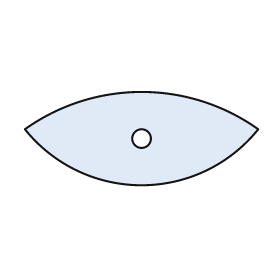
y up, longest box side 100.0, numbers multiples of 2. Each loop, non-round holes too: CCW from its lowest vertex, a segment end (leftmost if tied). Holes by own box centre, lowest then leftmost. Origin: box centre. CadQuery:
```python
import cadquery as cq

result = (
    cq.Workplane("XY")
    .moveTo(-50.0, 4.0)
    .threePointArc((0.0, -20.0), (50.0, 4.0))
    .threePointArc((0.0, 20.0), (-50.0, 4.0))
    .close()
    .moveTo(0.0, 0.0)
    .circle(4.0)
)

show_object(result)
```